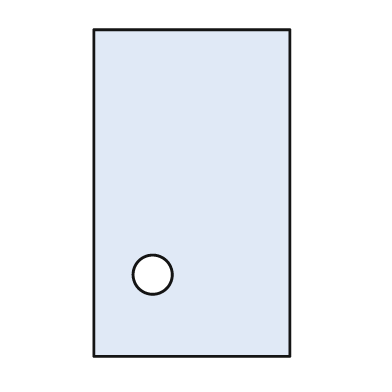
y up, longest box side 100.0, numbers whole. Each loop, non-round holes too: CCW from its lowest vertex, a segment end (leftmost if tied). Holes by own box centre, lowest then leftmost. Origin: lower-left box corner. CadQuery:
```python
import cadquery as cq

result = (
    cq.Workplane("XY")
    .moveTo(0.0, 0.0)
    .lineTo(60.0, 0.0)
    .lineTo(60.0, 100.0)
    .lineTo(0.0, 100.0)
    .close()
    .moveTo(18.0, 25.0)
    .circle(6.0)
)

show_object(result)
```